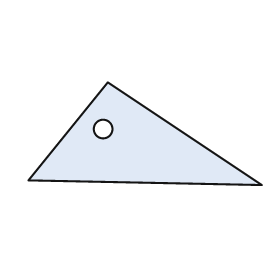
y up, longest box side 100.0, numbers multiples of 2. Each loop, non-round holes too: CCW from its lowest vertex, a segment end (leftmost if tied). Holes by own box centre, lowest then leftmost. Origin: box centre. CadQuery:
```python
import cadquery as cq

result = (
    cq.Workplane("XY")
    .moveTo(50.0, -22.0)
    .lineTo(-16.0, 22.0)
    .lineTo(-50.0, -20.0)
    .close()
    .moveTo(-18.0, 2.0)
    .circle(4.0)
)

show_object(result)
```